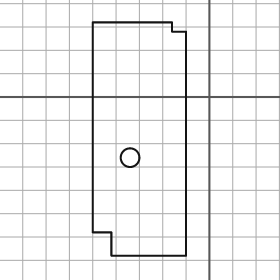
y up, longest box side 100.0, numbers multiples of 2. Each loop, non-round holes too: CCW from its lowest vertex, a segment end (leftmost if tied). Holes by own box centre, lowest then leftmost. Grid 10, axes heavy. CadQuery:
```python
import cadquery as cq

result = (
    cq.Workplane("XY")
    .moveTo(-42.0, -68.0)
    .lineTo(-10.0, -68.0)
    .lineTo(-10.0, 28.0)
    .lineTo(-16.0, 28.0)
    .lineTo(-16.0, 32.0)
    .lineTo(-50.0, 32.0)
    .lineTo(-50.0, -58.0)
    .lineTo(-42.0, -58.0)
    .close()
    .moveTo(-34.0, -26.0)
    .circle(4.0)
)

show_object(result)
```